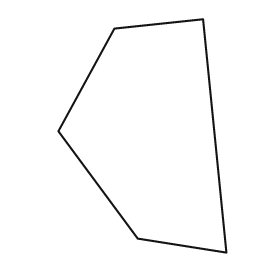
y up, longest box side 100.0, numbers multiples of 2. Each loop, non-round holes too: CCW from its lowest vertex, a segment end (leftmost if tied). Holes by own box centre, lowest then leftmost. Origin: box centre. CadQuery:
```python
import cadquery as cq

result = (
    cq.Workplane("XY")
    .moveTo(36.0, -50.0)
    .lineTo(26.0, 50.0)
    .lineTo(-12.0, 46.0)
    .lineTo(-36.0, 2.0)
    .lineTo(-2.0, -44.0)
    .close()
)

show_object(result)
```